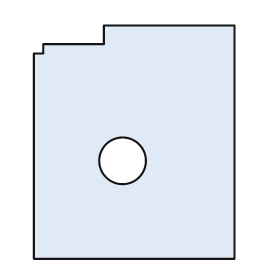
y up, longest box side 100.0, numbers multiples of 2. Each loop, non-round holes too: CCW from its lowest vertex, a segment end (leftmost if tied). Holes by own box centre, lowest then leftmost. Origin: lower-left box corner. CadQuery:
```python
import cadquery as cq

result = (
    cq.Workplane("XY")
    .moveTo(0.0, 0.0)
    .lineTo(86.0, 0.0)
    .lineTo(86.0, 100.0)
    .lineTo(30.0, 100.0)
    .lineTo(30.0, 92.0)
    .lineTo(4.0, 92.0)
    .lineTo(4.0, 88.0)
    .lineTo(0.0, 88.0)
    .close()
    .moveTo(38.0, 42.0)
    .circle(10.0)
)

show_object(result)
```